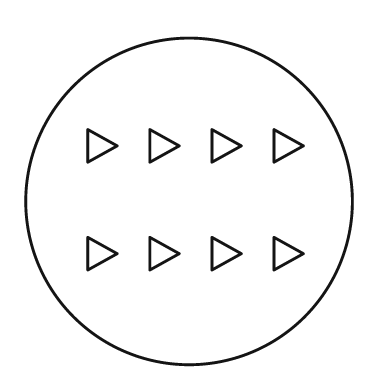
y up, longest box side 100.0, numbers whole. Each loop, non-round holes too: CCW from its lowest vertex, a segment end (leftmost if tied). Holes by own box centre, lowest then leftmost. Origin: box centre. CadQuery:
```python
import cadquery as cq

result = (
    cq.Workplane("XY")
    .moveTo(0.0, 0.0)
    .circle(50.0)
    .moveTo(-31.0, -21.0)
    .lineTo(-22.0, -16.0)
    .lineTo(-31.0, -11.0)
    .close()
    .moveTo(-12.0, -21.0)
    .lineTo(-3.0, -16.0)
    .lineTo(-12.0, -11.0)
    .close()
    .moveTo(7.0, -21.0)
    .lineTo(16.0, -16.0)
    .lineTo(7.0, -11.0)
    .close()
    .moveTo(26.0, -21.0)
    .lineTo(35.0, -16.0)
    .lineTo(26.0, -11.0)
    .close()
    .moveTo(-31.0, 12.0)
    .lineTo(-22.0, 17.0)
    .lineTo(-31.0, 22.0)
    .close()
    .moveTo(-12.0, 12.0)
    .lineTo(-3.0, 17.0)
    .lineTo(-12.0, 22.0)
    .close()
    .moveTo(7.0, 12.0)
    .lineTo(16.0, 17.0)
    .lineTo(7.0, 22.0)
    .close()
    .moveTo(26.0, 12.0)
    .lineTo(35.0, 17.0)
    .lineTo(26.0, 22.0)
    .close()
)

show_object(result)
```